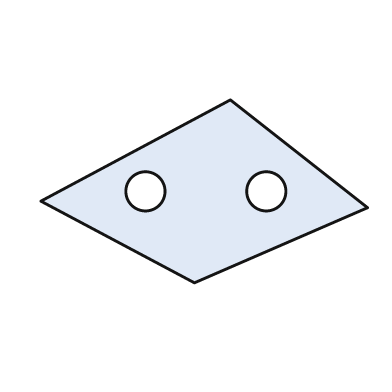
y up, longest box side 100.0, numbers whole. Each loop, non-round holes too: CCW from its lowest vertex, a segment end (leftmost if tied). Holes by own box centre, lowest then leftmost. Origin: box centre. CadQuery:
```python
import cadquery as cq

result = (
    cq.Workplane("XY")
    .moveTo(-3.0, -28.0)
    .lineTo(50.0, -5.0)
    .lineTo(8.0, 28.0)
    .lineTo(-50.0, -3.0)
    .close()
    .moveTo(-18.0, 0.0)
    .circle(6.0)
    .moveTo(19.0, 0.0)
    .circle(6.0)
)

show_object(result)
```